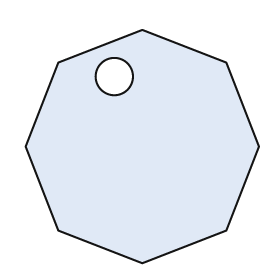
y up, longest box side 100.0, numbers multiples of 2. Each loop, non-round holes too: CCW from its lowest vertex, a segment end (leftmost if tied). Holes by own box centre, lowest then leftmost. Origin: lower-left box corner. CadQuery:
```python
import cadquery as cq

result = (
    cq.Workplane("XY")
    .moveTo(50.0, 0.0)
    .lineTo(86.0, 14.0)
    .lineTo(100.0, 50.0)
    .lineTo(86.0, 86.0)
    .lineTo(50.0, 100.0)
    .lineTo(14.0, 86.0)
    .lineTo(0.0, 50.0)
    .lineTo(14.0, 14.0)
    .close()
    .moveTo(38.0, 80.0)
    .circle(8.0)
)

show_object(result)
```